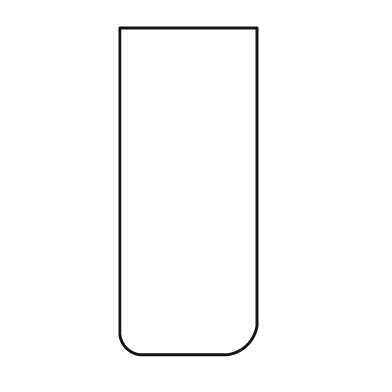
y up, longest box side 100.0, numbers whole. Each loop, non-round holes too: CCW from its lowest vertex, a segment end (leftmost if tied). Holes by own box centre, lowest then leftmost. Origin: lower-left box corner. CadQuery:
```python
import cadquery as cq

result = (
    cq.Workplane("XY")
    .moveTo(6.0, 0.0)
    .lineTo(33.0, 0.0)
    .threePointArc((39.0, 3.0), (42.0, 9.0))
    .lineTo(42.0, 100.0)
    .lineTo(0.0, 100.0)
    .lineTo(0.0, 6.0)
    .threePointArc((2.0, 2.0), (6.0, 0.0))
    .close()
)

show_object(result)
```